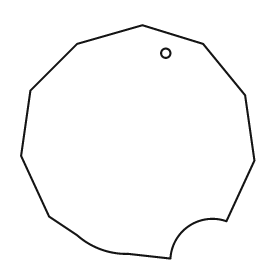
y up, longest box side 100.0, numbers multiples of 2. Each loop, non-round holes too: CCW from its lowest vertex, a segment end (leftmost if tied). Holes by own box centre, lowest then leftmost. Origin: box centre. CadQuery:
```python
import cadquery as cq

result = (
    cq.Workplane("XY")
    .moveTo(14.0, -50.0)
    .threePointArc((22.0, -36.0), (38.0, -34.0))
    .lineTo(50.0, -8.0)
    .lineTo(46.0, 20.0)
    .lineTo(28.0, 42.0)
    .lineTo(2.0, 50.0)
    .lineTo(-26.0, 42.0)
    .lineTo(-46.0, 22.0)
    .lineTo(-50.0, -6.0)
    .lineTo(-38.0, -32.0)
    .lineTo(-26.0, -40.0)
    .threePointArc((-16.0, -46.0), (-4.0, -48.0))
    .close()
    .moveTo(12.0, 38.0)
    .circle(2.0)
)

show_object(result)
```